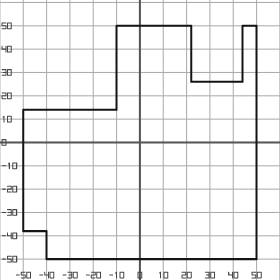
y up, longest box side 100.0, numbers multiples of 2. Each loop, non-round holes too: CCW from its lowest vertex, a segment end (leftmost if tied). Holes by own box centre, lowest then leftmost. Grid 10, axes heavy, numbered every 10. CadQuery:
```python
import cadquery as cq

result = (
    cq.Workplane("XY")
    .moveTo(-40.0, -50.0)
    .lineTo(50.0, -50.0)
    .lineTo(50.0, 50.0)
    .lineTo(44.0, 50.0)
    .lineTo(44.0, 26.0)
    .lineTo(22.0, 26.0)
    .lineTo(22.0, 50.0)
    .lineTo(-10.0, 50.0)
    .lineTo(-10.0, 14.0)
    .lineTo(-50.0, 14.0)
    .lineTo(-50.0, -38.0)
    .lineTo(-40.0, -38.0)
    .close()
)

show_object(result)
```